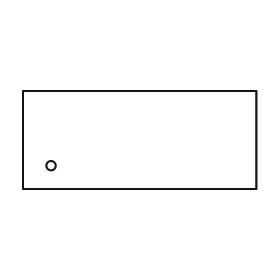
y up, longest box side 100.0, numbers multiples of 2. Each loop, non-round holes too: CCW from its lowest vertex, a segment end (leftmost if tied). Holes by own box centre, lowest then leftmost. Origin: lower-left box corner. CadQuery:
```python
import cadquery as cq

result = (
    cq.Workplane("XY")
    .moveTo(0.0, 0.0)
    .lineTo(100.0, 0.0)
    .lineTo(100.0, 42.0)
    .lineTo(0.0, 42.0)
    .close()
    .moveTo(12.0, 10.0)
    .circle(2.0)
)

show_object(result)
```